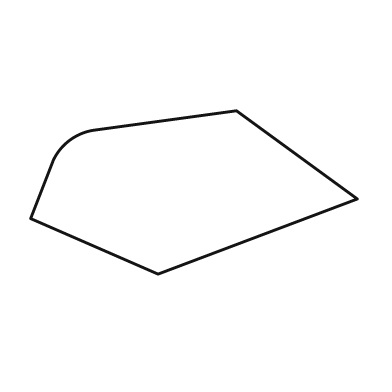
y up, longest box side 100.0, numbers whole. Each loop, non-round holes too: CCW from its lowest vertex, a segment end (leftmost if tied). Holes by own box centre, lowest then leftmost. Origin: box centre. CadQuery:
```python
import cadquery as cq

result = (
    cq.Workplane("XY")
    .moveTo(-11.0, -25.0)
    .lineTo(50.0, -2.0)
    .lineTo(13.0, 25.0)
    .lineTo(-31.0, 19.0)
    .threePointArc((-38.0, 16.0), (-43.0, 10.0))
    .lineTo(-50.0, -8.0)
    .close()
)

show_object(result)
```